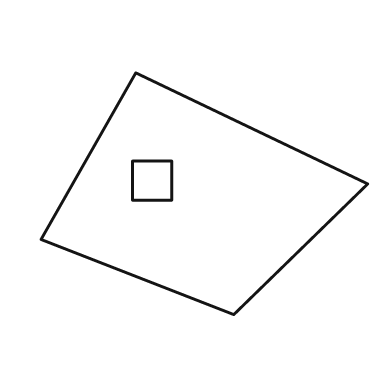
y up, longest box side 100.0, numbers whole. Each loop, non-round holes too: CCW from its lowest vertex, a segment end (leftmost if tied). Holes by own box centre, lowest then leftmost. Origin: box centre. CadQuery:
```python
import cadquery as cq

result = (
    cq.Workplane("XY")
    .moveTo(9.0, -37.0)
    .lineTo(50.0, 3.0)
    .lineTo(-21.0, 37.0)
    .lineTo(-50.0, -14.0)
    .close()
    .moveTo(-22.0, -2.0)
    .lineTo(-10.0, -2.0)
    .lineTo(-10.0, 10.0)
    .lineTo(-22.0, 10.0)
    .close()
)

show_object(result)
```